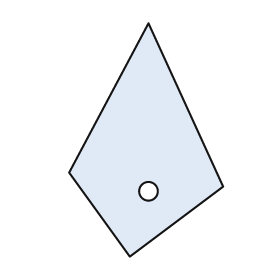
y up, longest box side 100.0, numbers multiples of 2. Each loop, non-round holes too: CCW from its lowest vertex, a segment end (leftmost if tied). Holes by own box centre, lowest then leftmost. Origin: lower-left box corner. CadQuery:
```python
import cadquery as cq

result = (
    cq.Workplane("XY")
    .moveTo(26.0, 0.0)
    .lineTo(66.0, 30.0)
    .lineTo(34.0, 100.0)
    .lineTo(0.0, 36.0)
    .close()
    .moveTo(34.0, 28.0)
    .circle(4.0)
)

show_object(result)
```